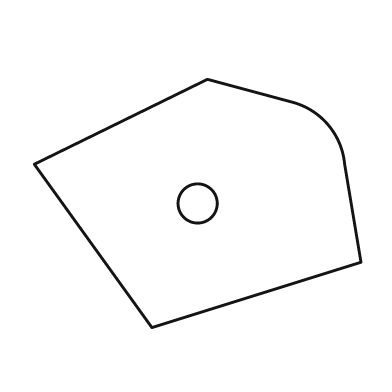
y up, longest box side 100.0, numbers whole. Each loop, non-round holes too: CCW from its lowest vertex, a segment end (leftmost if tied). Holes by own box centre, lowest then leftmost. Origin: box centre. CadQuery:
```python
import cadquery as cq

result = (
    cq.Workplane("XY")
    .moveTo(-14.0, -38.0)
    .lineTo(50.0, -18.0)
    .lineTo(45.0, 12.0)
    .threePointArc((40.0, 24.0), (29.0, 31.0))
    .lineTo(3.0, 38.0)
    .lineTo(-50.0, 12.0)
    .close()
    .moveTo(0.0, 0.0)
    .circle(6.0)
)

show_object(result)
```